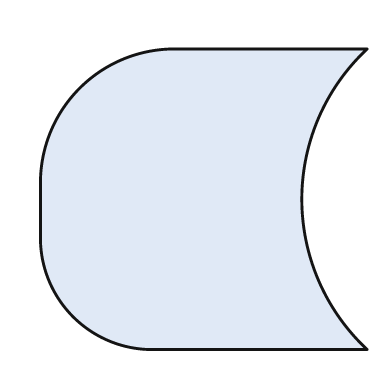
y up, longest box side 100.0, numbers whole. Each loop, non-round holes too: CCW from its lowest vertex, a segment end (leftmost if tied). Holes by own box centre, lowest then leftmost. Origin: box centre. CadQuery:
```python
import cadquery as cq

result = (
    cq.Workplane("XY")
    .moveTo(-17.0, -46.0)
    .lineTo(50.0, -46.0)
    .threePointArc((30.0, 0.0), (50.0, 46.0))
    .lineTo(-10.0, 46.0)
    .threePointArc((-38.0, 34.0), (-50.0, 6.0))
    .lineTo(-50.0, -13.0)
    .threePointArc((-40.0, -36.0), (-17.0, -46.0))
    .close()
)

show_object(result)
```